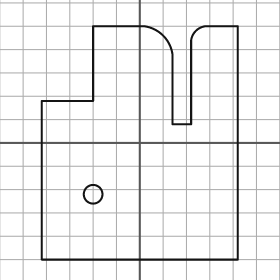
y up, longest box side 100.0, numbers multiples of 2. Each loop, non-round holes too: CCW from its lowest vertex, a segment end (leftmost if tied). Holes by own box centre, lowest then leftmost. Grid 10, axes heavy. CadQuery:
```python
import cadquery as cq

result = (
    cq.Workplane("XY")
    .moveTo(-42.0, -50.0)
    .lineTo(42.0, -50.0)
    .lineTo(42.0, 50.0)
    .lineTo(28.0, 50.0)
    .threePointArc((24.0, 48.0), (22.0, 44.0))
    .lineTo(22.0, 8.0)
    .lineTo(14.0, 8.0)
    .lineTo(14.0, 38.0)
    .threePointArc((10.0, 46.0), (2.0, 50.0))
    .lineTo(-20.0, 50.0)
    .lineTo(-20.0, 18.0)
    .lineTo(-42.0, 18.0)
    .close()
    .moveTo(-20.0, -22.0)
    .circle(4.0)
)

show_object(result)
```